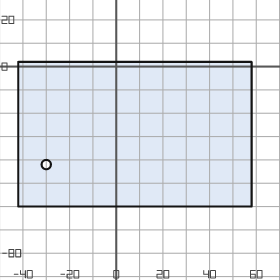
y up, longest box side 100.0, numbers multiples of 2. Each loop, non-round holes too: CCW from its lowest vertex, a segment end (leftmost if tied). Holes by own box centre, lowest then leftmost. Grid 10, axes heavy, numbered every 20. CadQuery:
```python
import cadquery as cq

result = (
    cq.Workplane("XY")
    .moveTo(-42.0, -60.0)
    .lineTo(58.0, -60.0)
    .lineTo(58.0, 2.0)
    .lineTo(-42.0, 2.0)
    .close()
    .moveTo(-30.0, -42.0)
    .circle(2.0)
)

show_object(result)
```